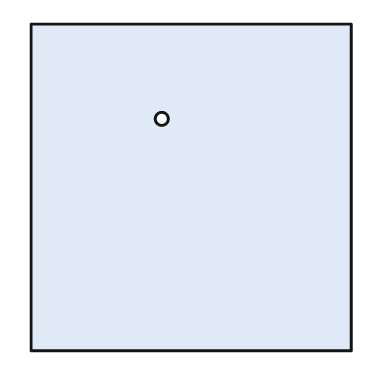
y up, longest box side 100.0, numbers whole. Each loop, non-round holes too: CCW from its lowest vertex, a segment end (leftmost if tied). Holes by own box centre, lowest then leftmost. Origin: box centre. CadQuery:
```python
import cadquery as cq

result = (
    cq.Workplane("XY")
    .moveTo(-49.0, -50.0)
    .lineTo(49.0, -50.0)
    .lineTo(49.0, 50.0)
    .lineTo(-49.0, 50.0)
    .close()
    .moveTo(-9.0, 21.0)
    .circle(2.0)
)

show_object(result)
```